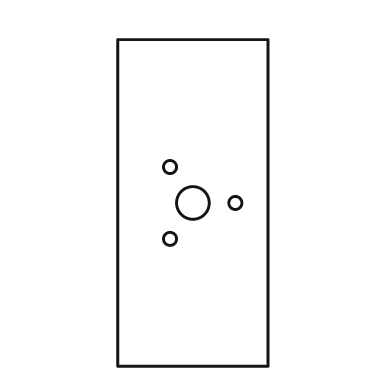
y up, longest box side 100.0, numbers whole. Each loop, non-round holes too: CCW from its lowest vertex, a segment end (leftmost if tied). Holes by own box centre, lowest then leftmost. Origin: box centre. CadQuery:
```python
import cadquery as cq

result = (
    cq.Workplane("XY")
    .moveTo(-23.0, -50.0)
    .lineTo(23.0, -50.0)
    .lineTo(23.0, 50.0)
    .lineTo(-23.0, 50.0)
    .close()
    .moveTo(-7.0, -11.0)
    .circle(2.0)
    .moveTo(0.0, 0.0)
    .circle(5.0)
    .moveTo(13.0, 0.0)
    .circle(2.0)
    .moveTo(-7.0, 11.0)
    .circle(2.0)
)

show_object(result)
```